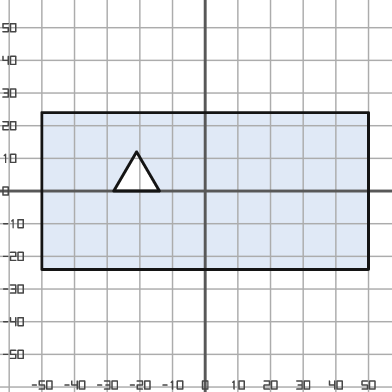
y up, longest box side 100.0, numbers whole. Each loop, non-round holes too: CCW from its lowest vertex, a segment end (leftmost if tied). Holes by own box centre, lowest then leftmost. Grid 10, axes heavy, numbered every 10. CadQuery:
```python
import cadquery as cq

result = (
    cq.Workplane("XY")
    .moveTo(-50.0, -24.0)
    .lineTo(50.0, -24.0)
    .lineTo(50.0, 24.0)
    .lineTo(-50.0, 24.0)
    .close()
    .moveTo(-28.0, 0.0)
    .lineTo(-14.0, 0.0)
    .lineTo(-21.0, 12.0)
    .close()
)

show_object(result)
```